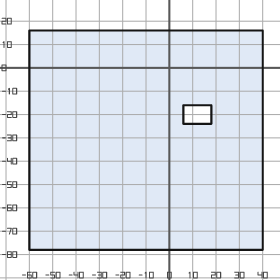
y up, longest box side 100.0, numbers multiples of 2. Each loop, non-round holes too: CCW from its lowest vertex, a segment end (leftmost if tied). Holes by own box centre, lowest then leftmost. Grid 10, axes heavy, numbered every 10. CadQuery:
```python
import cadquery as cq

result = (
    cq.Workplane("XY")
    .moveTo(-60.0, -78.0)
    .lineTo(40.0, -78.0)
    .lineTo(40.0, 16.0)
    .lineTo(-60.0, 16.0)
    .close()
    .moveTo(6.0, -24.0)
    .lineTo(18.0, -24.0)
    .lineTo(18.0, -16.0)
    .lineTo(6.0, -16.0)
    .close()
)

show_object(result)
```